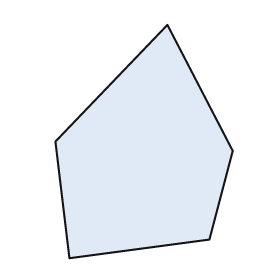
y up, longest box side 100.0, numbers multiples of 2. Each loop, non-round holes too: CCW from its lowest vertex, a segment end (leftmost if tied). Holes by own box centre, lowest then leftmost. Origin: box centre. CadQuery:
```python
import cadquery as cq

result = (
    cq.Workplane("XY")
    .moveTo(-32.0, -50.0)
    .lineTo(28.0, -42.0)
    .lineTo(38.0, -4.0)
    .lineTo(10.0, 50.0)
    .lineTo(-38.0, 0.0)
    .close()
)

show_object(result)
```